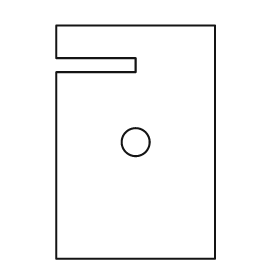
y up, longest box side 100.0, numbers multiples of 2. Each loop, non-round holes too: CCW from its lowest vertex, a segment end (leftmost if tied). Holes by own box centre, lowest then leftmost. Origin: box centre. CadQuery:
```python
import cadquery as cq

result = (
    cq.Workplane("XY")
    .moveTo(-34.0, -50.0)
    .lineTo(34.0, -50.0)
    .lineTo(34.0, 50.0)
    .lineTo(-34.0, 50.0)
    .lineTo(-34.0, 36.0)
    .lineTo(0.0, 36.0)
    .lineTo(0.0, 30.0)
    .lineTo(-34.0, 30.0)
    .close()
    .moveTo(0.0, 0.0)
    .circle(6.0)
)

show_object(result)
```